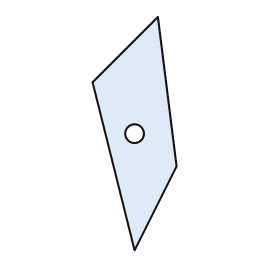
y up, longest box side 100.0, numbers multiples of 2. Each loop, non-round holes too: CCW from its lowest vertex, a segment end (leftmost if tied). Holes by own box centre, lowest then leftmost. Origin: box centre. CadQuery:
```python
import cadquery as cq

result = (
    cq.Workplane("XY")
    .moveTo(0.0, -50.0)
    .lineTo(18.0, -14.0)
    .lineTo(10.0, 50.0)
    .lineTo(-18.0, 22.0)
    .close()
    .moveTo(0.0, 0.0)
    .circle(4.0)
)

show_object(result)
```